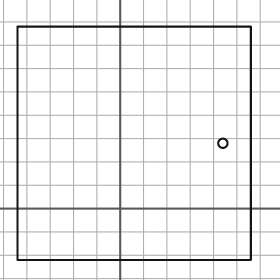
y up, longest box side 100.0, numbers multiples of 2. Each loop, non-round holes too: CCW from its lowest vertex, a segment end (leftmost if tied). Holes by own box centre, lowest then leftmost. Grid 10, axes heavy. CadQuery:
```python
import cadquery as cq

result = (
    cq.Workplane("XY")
    .moveTo(-44.0, -22.0)
    .lineTo(56.0, -22.0)
    .lineTo(56.0, 78.0)
    .lineTo(-44.0, 78.0)
    .close()
    .moveTo(44.0, 28.0)
    .circle(2.0)
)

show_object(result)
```